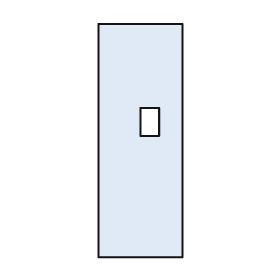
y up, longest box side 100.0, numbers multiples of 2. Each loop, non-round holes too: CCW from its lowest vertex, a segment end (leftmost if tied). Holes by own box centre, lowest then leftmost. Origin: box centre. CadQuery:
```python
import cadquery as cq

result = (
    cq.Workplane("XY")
    .moveTo(-18.0, -50.0)
    .lineTo(18.0, -50.0)
    .lineTo(18.0, 50.0)
    .lineTo(-18.0, 50.0)
    .close()
    .moveTo(0.0, 2.0)
    .lineTo(8.0, 2.0)
    .lineTo(8.0, 14.0)
    .lineTo(0.0, 14.0)
    .close()
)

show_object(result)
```